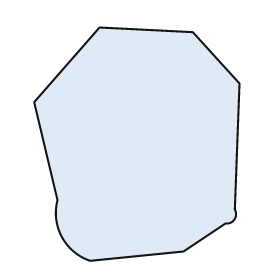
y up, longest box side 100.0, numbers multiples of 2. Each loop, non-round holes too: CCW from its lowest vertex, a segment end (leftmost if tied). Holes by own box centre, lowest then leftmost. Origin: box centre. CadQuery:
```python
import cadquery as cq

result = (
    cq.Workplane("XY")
    .moveTo(-20.0, -50.0)
    .lineTo(20.0, -46.0)
    .lineTo(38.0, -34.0)
    .threePointArc((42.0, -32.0), (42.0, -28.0))
    .lineTo(44.0, 26.0)
    .lineTo(24.0, 48.0)
    .lineTo(-16.0, 50.0)
    .lineTo(-44.0, 18.0)
    .lineTo(-34.0, -24.0)
    .threePointArc((-32.0, -40.0), (-20.0, -50.0))
    .close()
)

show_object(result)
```